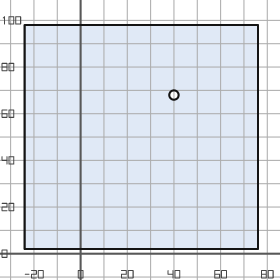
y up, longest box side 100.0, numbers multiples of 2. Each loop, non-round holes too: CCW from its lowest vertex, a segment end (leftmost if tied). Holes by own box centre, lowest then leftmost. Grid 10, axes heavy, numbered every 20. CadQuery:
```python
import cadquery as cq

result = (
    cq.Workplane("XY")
    .moveTo(-24.0, 2.0)
    .lineTo(76.0, 2.0)
    .lineTo(76.0, 98.0)
    .lineTo(-24.0, 98.0)
    .close()
    .moveTo(40.0, 68.0)
    .circle(2.0)
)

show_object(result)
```